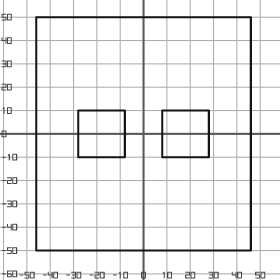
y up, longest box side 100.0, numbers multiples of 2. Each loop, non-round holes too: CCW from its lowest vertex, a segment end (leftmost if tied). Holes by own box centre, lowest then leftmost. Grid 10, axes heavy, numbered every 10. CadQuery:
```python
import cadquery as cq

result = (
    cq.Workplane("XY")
    .moveTo(-46.0, -50.0)
    .lineTo(46.0, -50.0)
    .lineTo(46.0, 50.0)
    .lineTo(-46.0, 50.0)
    .close()
    .moveTo(-28.0, -10.0)
    .lineTo(-8.0, -10.0)
    .lineTo(-8.0, 10.0)
    .lineTo(-28.0, 10.0)
    .close()
    .moveTo(8.0, -10.0)
    .lineTo(28.0, -10.0)
    .lineTo(28.0, 10.0)
    .lineTo(8.0, 10.0)
    .close()
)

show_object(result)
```